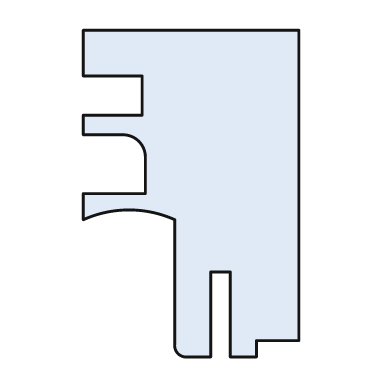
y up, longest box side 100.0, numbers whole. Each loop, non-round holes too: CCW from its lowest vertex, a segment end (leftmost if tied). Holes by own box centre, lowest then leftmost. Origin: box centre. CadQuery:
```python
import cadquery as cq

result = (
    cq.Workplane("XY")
    .moveTo(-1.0, -50.0)
    .lineTo(6.0, -50.0)
    .lineTo(6.0, -24.0)
    .lineTo(12.0, -24.0)
    .lineTo(12.0, -50.0)
    .lineTo(20.0, -50.0)
    .lineTo(20.0, -45.0)
    .lineTo(33.0, -45.0)
    .lineTo(33.0, 50.0)
    .lineTo(-33.0, 50.0)
    .lineTo(-33.0, 36.0)
    .lineTo(-15.0, 36.0)
    .lineTo(-15.0, 24.0)
    .lineTo(-33.0, 24.0)
    .lineTo(-33.0, 18.0)
    .lineTo(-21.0, 18.0)
    .threePointArc((-16.0, 16.0), (-14.0, 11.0))
    .lineTo(-14.0, 0.0)
    .lineTo(-33.0, 0.0)
    .lineTo(-33.0, -8.0)
    .threePointArc((-19.0, -5.0), (-5.0, -8.0))
    .lineTo(-5.0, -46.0)
    .threePointArc((-4.0, -49.0), (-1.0, -50.0))
    .close()
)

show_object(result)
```